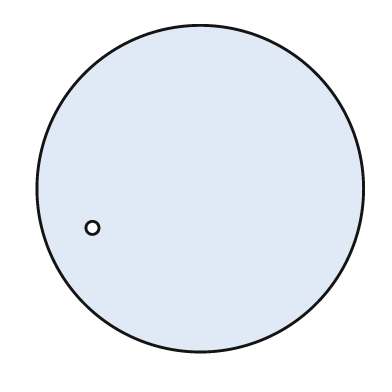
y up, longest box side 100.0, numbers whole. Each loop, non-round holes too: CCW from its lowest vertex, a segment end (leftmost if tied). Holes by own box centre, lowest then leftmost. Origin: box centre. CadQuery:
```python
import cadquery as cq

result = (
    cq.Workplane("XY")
    .moveTo(0.0, 0.0)
    .circle(50.0)
    .moveTo(-33.0, -12.0)
    .circle(2.0)
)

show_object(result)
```